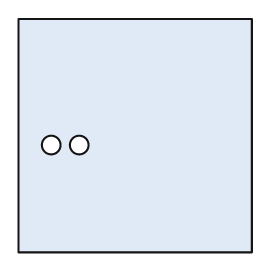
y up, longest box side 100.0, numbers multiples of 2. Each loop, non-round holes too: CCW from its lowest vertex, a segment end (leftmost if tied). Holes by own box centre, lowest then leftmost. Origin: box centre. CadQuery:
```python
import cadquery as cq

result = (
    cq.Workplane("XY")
    .moveTo(-50.0, -50.0)
    .lineTo(50.0, -50.0)
    .lineTo(50.0, 50.0)
    .lineTo(-50.0, 50.0)
    .close()
    .moveTo(-36.0, -4.0)
    .circle(4.0)
    .moveTo(-24.0, -4.0)
    .circle(4.0)
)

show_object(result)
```